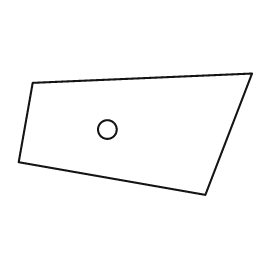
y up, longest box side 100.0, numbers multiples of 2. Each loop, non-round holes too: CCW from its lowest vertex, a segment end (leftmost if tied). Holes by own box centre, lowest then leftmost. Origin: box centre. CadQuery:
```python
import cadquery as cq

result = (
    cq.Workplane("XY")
    .moveTo(30.0, -26.0)
    .lineTo(50.0, 26.0)
    .lineTo(-44.0, 22.0)
    .lineTo(-50.0, -12.0)
    .close()
    .moveTo(-12.0, 2.0)
    .circle(4.0)
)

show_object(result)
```